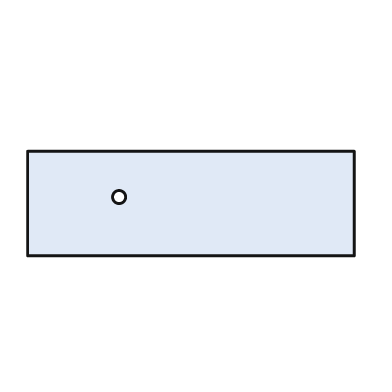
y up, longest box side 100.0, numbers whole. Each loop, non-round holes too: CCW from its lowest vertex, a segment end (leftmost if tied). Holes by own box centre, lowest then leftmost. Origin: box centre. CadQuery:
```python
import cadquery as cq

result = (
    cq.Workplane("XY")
    .moveTo(-50.0, -16.0)
    .lineTo(50.0, -16.0)
    .lineTo(50.0, 16.0)
    .lineTo(-50.0, 16.0)
    .close()
    .moveTo(-22.0, 2.0)
    .circle(2.0)
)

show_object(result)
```